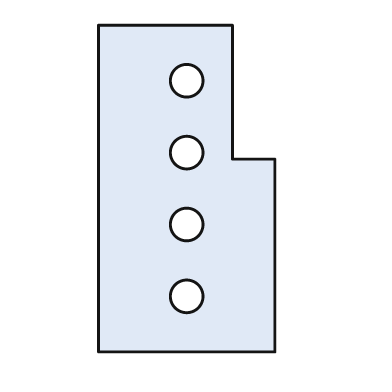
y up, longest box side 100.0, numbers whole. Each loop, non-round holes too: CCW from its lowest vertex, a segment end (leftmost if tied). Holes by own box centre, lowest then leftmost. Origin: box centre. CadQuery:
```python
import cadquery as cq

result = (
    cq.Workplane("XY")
    .moveTo(-27.0, -50.0)
    .lineTo(27.0, -50.0)
    .lineTo(27.0, 9.0)
    .lineTo(14.0, 9.0)
    .lineTo(14.0, 50.0)
    .lineTo(-27.0, 50.0)
    .close()
    .moveTo(0.0, -33.0)
    .circle(5.0)
    .moveTo(0.0, -11.0)
    .circle(5.0)
    .moveTo(0.0, 11.0)
    .circle(5.0)
    .moveTo(0.0, 33.0)
    .circle(5.0)
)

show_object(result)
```